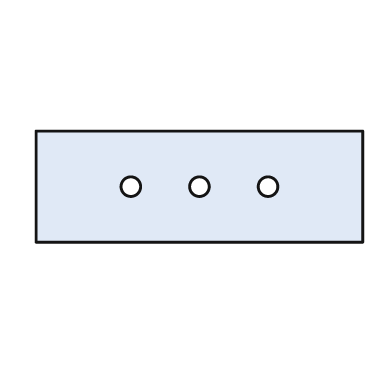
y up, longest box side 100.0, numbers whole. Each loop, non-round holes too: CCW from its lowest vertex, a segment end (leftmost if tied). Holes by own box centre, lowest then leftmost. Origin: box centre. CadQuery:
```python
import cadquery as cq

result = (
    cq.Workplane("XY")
    .moveTo(-50.0, -17.0)
    .lineTo(50.0, -17.0)
    .lineTo(50.0, 17.0)
    .lineTo(-50.0, 17.0)
    .close()
    .moveTo(-21.0, 0.0)
    .circle(3.0)
    .moveTo(0.0, 0.0)
    .circle(3.0)
    .moveTo(21.0, 0.0)
    .circle(3.0)
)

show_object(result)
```